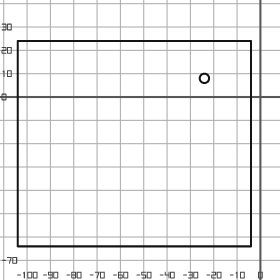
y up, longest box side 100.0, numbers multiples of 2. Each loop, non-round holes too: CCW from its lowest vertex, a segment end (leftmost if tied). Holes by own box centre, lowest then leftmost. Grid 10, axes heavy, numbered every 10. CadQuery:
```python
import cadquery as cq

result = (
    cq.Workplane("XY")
    .moveTo(-104.0, -64.0)
    .lineTo(-4.0, -64.0)
    .lineTo(-4.0, 24.0)
    .lineTo(-104.0, 24.0)
    .close()
    .moveTo(-24.0, 8.0)
    .circle(2.0)
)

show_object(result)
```